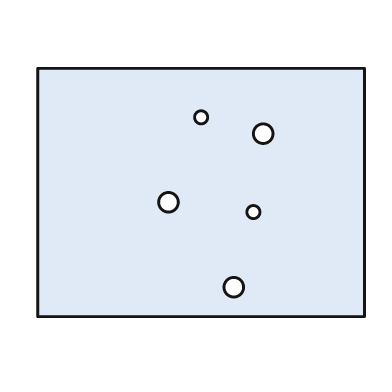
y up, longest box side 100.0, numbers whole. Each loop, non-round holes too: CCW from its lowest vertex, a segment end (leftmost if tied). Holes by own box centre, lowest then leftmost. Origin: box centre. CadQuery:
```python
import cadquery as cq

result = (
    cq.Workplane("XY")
    .moveTo(-50.0, -38.0)
    .lineTo(50.0, -38.0)
    .lineTo(50.0, 38.0)
    .lineTo(-50.0, 38.0)
    .close()
    .moveTo(10.0, -29.0)
    .circle(3.0)
    .moveTo(16.0, -6.0)
    .circle(2.0)
    .moveTo(-10.0, -3.0)
    .circle(3.0)
    .moveTo(19.0, 18.0)
    .circle(3.0)
    .moveTo(0.0, 23.0)
    .circle(2.0)
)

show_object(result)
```